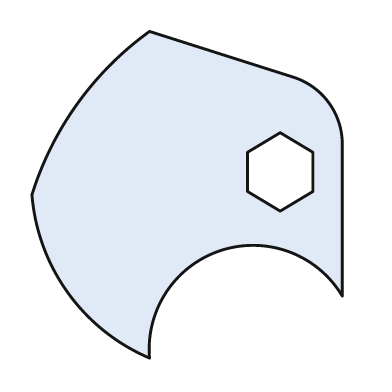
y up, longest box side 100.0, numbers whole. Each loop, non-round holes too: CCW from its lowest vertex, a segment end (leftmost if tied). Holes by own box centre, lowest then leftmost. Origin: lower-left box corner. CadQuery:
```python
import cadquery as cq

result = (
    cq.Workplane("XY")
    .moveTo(36.0, 0.0)
    .threePointArc((58.0, 33.0), (95.0, 19.0))
    .lineTo(95.0, 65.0)
    .threePointArc((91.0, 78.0), (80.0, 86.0))
    .lineTo(36.0, 100.0)
    .threePointArc((14.0, 78.0), (0.0, 50.0))
    .threePointArc((11.0, 20.0), (36.0, 0.0))
    .close()
    .moveTo(76.0, 45.0)
    .lineTo(86.0, 51.0)
    .lineTo(86.0, 63.0)
    .lineTo(76.0, 69.0)
    .lineTo(66.0, 63.0)
    .lineTo(66.0, 51.0)
    .close()
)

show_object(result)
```